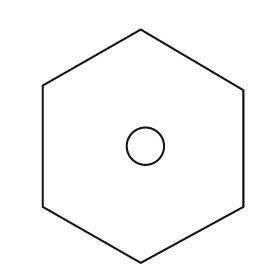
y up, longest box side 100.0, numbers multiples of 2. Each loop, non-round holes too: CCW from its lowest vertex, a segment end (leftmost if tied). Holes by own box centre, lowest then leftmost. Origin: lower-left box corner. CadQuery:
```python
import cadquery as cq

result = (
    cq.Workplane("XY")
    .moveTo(42.0, 0.0)
    .lineTo(86.0, 24.0)
    .lineTo(86.0, 74.0)
    .lineTo(42.0, 100.0)
    .lineTo(0.0, 76.0)
    .lineTo(0.0, 24.0)
    .close()
    .moveTo(44.0, 50.0)
    .circle(8.0)
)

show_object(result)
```